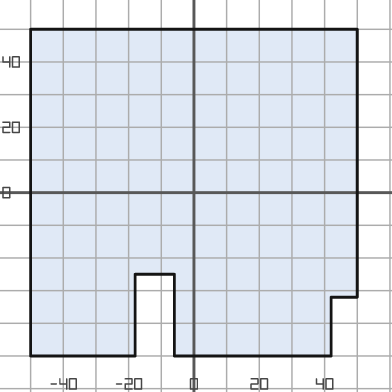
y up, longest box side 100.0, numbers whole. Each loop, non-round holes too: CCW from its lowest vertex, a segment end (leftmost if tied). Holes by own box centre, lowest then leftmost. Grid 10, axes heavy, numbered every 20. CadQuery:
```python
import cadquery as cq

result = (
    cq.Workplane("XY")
    .moveTo(-50.0, -50.0)
    .lineTo(-18.0, -50.0)
    .lineTo(-18.0, -25.0)
    .lineTo(-6.0, -25.0)
    .lineTo(-6.0, -50.0)
    .lineTo(42.0, -50.0)
    .lineTo(42.0, -32.0)
    .lineTo(50.0, -32.0)
    .lineTo(50.0, 50.0)
    .lineTo(-50.0, 50.0)
    .close()
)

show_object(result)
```